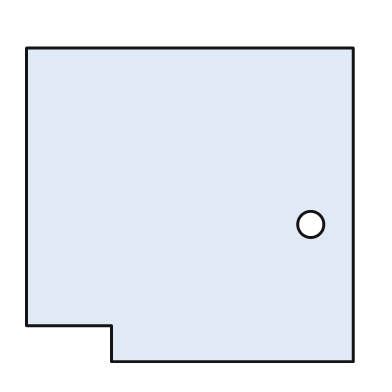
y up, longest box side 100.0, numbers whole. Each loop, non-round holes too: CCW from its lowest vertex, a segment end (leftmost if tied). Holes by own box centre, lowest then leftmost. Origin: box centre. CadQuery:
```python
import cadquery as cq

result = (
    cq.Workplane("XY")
    .moveTo(-24.0, -48.0)
    .lineTo(50.0, -48.0)
    .lineTo(50.0, 48.0)
    .lineTo(-50.0, 48.0)
    .lineTo(-50.0, -37.0)
    .lineTo(-24.0, -37.0)
    .close()
    .moveTo(37.0, -6.0)
    .circle(4.0)
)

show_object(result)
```